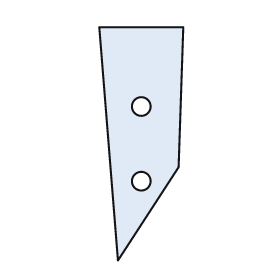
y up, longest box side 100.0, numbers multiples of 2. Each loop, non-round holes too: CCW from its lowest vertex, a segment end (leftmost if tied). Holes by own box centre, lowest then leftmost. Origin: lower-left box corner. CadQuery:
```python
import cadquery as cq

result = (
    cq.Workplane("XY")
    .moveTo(8.0, 0.0)
    .lineTo(34.0, 40.0)
    .lineTo(36.0, 100.0)
    .lineTo(0.0, 100.0)
    .close()
    .moveTo(18.0, 34.0)
    .circle(4.0)
    .moveTo(18.0, 66.0)
    .circle(4.0)
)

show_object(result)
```